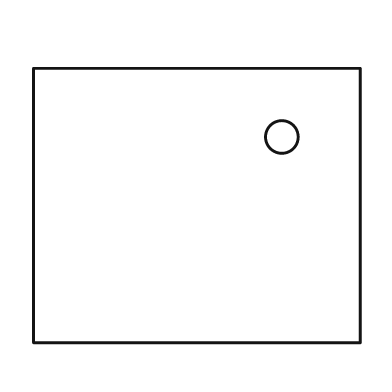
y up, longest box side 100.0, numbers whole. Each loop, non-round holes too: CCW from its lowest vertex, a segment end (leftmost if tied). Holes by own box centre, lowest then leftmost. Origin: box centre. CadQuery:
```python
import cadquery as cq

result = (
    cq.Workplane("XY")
    .moveTo(-50.0, -42.0)
    .lineTo(50.0, -42.0)
    .lineTo(50.0, 42.0)
    .lineTo(-50.0, 42.0)
    .close()
    .moveTo(26.0, 21.0)
    .circle(5.0)
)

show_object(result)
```